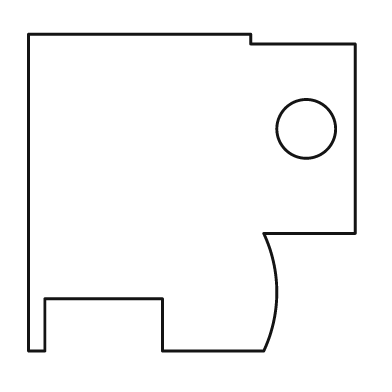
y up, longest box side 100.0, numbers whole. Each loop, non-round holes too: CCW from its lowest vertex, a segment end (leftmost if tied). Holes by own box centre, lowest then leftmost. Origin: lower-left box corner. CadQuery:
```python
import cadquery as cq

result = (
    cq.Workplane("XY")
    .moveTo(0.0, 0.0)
    .lineTo(5.0, 0.0)
    .lineTo(5.0, 16.0)
    .lineTo(41.0, 16.0)
    .lineTo(41.0, 0.0)
    .lineTo(72.0, 0.0)
    .threePointArc((76.0, 18.0), (72.0, 36.0))
    .lineTo(100.0, 36.0)
    .lineTo(100.0, 94.0)
    .lineTo(68.0, 94.0)
    .lineTo(68.0, 97.0)
    .lineTo(0.0, 97.0)
    .close()
    .moveTo(85.0, 68.0)
    .circle(9.0)
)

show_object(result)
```